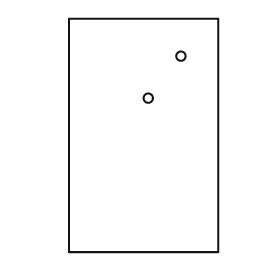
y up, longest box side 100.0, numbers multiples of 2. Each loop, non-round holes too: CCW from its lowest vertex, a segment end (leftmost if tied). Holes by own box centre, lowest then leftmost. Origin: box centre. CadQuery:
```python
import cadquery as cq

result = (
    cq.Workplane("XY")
    .moveTo(-32.0, -50.0)
    .lineTo(32.0, -50.0)
    .lineTo(32.0, 50.0)
    .lineTo(-32.0, 50.0)
    .close()
    .moveTo(2.0, 16.0)
    .circle(2.0)
    .moveTo(16.0, 34.0)
    .circle(2.0)
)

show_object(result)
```